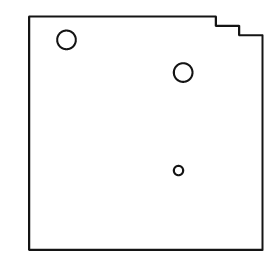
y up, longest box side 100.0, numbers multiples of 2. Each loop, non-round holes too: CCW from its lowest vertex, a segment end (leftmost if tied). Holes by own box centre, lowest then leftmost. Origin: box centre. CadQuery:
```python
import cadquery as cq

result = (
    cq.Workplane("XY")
    .moveTo(-50.0, -50.0)
    .lineTo(50.0, -50.0)
    .lineTo(50.0, 42.0)
    .lineTo(40.0, 42.0)
    .lineTo(40.0, 46.0)
    .lineTo(30.0, 46.0)
    .lineTo(30.0, 50.0)
    .lineTo(-50.0, 50.0)
    .close()
    .moveTo(14.0, -16.0)
    .circle(2.0)
    .moveTo(16.0, 26.0)
    .circle(4.0)
    .moveTo(-34.0, 40.0)
    .circle(4.0)
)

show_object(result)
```